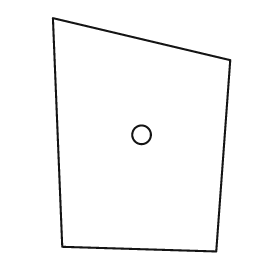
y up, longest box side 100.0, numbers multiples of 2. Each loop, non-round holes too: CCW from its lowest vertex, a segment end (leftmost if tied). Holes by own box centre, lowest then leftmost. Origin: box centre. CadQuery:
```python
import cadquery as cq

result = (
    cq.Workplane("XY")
    .moveTo(32.0, -50.0)
    .lineTo(38.0, 32.0)
    .lineTo(-38.0, 50.0)
    .lineTo(-34.0, -48.0)
    .close()
    .moveTo(0.0, 0.0)
    .circle(4.0)
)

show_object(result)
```